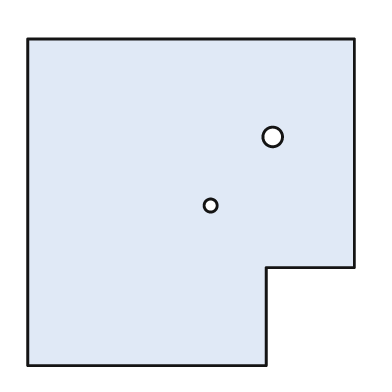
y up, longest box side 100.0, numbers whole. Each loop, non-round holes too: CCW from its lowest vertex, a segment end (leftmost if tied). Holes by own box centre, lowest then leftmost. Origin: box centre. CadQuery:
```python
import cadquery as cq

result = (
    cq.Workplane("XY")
    .moveTo(-50.0, -50.0)
    .lineTo(23.0, -50.0)
    .lineTo(23.0, -20.0)
    .lineTo(50.0, -20.0)
    .lineTo(50.0, 50.0)
    .lineTo(-50.0, 50.0)
    .close()
    .moveTo(6.0, -1.0)
    .circle(2.0)
    .moveTo(25.0, 20.0)
    .circle(3.0)
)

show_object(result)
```